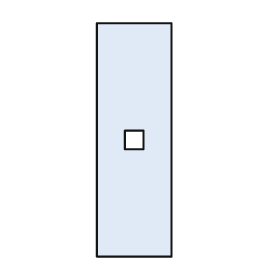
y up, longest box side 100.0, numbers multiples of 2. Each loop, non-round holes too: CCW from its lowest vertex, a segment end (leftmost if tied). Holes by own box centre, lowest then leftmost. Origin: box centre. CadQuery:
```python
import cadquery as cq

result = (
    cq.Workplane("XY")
    .moveTo(-16.0, -50.0)
    .lineTo(16.0, -50.0)
    .lineTo(16.0, 50.0)
    .lineTo(-16.0, 50.0)
    .close()
    .moveTo(-4.0, -4.0)
    .lineTo(4.0, -4.0)
    .lineTo(4.0, 4.0)
    .lineTo(-4.0, 4.0)
    .close()
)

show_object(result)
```